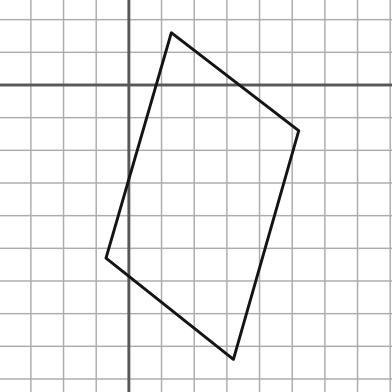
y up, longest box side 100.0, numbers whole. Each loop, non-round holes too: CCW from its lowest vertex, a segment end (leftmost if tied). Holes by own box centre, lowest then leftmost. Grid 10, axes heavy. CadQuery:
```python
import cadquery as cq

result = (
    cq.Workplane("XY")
    .moveTo(32.0, -84.0)
    .lineTo(52.0, -14.0)
    .lineTo(13.0, 16.0)
    .lineTo(-7.0, -53.0)
    .close()
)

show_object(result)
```